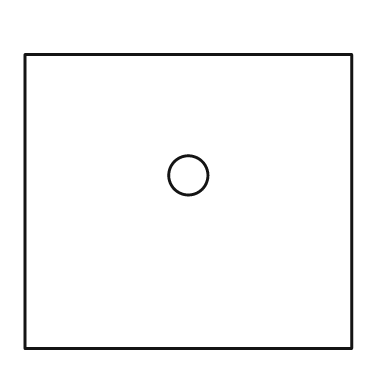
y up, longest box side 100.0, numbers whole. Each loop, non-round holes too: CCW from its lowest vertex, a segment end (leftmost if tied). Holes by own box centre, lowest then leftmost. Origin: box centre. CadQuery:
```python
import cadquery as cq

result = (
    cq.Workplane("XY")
    .moveTo(-50.0, -45.0)
    .lineTo(50.0, -45.0)
    .lineTo(50.0, 45.0)
    .lineTo(-50.0, 45.0)
    .close()
    .moveTo(0.0, 8.0)
    .circle(6.0)
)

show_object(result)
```